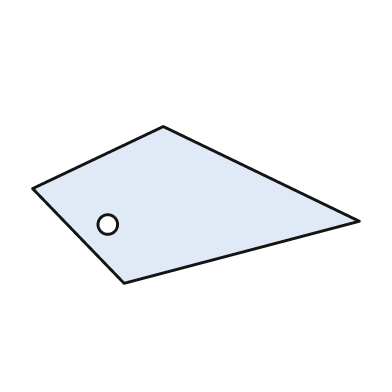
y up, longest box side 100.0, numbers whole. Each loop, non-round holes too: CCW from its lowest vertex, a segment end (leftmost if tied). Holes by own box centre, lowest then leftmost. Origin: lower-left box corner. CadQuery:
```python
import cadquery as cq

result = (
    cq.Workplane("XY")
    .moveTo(28.0, 0.0)
    .lineTo(100.0, 19.0)
    .lineTo(40.0, 48.0)
    .lineTo(0.0, 29.0)
    .close()
    .moveTo(23.0, 18.0)
    .circle(3.0)
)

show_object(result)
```